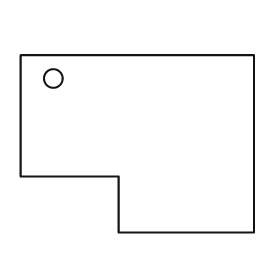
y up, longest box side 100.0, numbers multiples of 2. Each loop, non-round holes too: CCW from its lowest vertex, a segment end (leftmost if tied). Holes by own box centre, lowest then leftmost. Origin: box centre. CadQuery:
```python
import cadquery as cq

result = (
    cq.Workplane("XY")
    .moveTo(-8.0, -38.0)
    .lineTo(50.0, -38.0)
    .lineTo(50.0, 38.0)
    .lineTo(-50.0, 38.0)
    .lineTo(-50.0, -14.0)
    .lineTo(-8.0, -14.0)
    .close()
    .moveTo(-36.0, 28.0)
    .circle(4.0)
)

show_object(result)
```